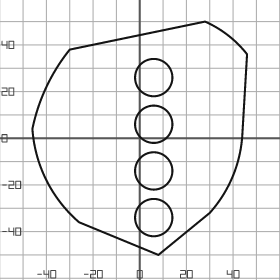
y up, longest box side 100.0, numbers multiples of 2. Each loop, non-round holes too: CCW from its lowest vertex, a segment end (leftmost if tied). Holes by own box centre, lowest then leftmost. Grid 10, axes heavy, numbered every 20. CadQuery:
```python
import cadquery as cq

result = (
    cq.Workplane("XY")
    .moveTo(8.0, -50.0)
    .lineTo(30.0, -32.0)
    .threePointArc((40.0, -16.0), (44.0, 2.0))
    .lineTo(46.0, 36.0)
    .threePointArc((38.0, 44.0), (28.0, 50.0))
    .lineTo(-30.0, 38.0)
    .threePointArc((-40.0, 22.0), (-46.0, 4.0))
    .threePointArc((-40.0, -18.0), (-26.0, -36.0))
    .close()
    .moveTo(6.0, -34.0)
    .circle(8.0)
    .moveTo(6.0, -14.0)
    .circle(8.0)
    .moveTo(6.0, 6.0)
    .circle(8.0)
    .moveTo(6.0, 26.0)
    .circle(8.0)
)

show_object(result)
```